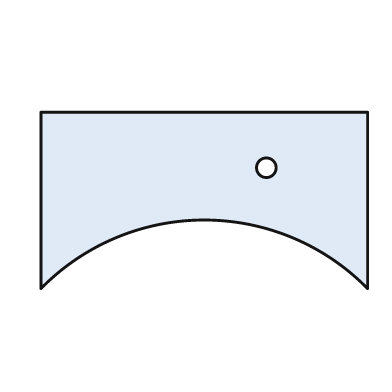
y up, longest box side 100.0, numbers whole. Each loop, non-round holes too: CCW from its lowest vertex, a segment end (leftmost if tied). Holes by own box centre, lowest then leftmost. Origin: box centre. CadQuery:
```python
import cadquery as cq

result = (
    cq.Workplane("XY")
    .moveTo(-50.0, -27.0)
    .threePointArc((0.0, -6.0), (50.0, -27.0))
    .lineTo(50.0, 27.0)
    .lineTo(-50.0, 27.0)
    .close()
    .moveTo(19.0, 10.0)
    .circle(3.0)
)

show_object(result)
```